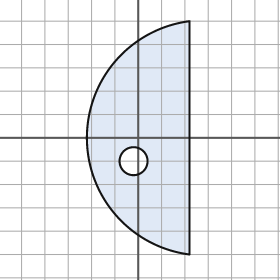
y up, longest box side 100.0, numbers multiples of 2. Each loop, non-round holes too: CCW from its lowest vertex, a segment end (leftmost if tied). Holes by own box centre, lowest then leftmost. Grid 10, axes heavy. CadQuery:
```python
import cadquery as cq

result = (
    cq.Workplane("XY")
    .moveTo(22.0, -50.0)
    .lineTo(22.0, 50.0)
    .threePointArc((-22.0, 0.0), (22.0, -50.0))
    .close()
    .moveTo(-2.0, -10.0)
    .circle(6.0)
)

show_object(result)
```